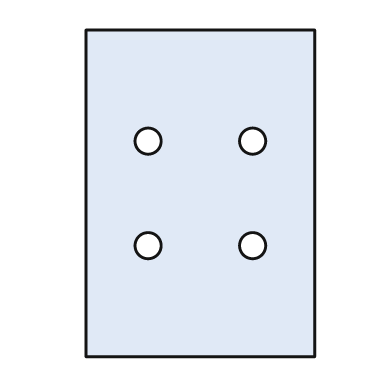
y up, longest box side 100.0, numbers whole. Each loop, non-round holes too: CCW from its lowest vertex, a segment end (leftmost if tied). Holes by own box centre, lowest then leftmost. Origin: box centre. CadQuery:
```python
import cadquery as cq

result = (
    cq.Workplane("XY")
    .moveTo(-35.0, -50.0)
    .lineTo(35.0, -50.0)
    .lineTo(35.0, 50.0)
    .lineTo(-35.0, 50.0)
    .close()
    .moveTo(-16.0, -16.0)
    .circle(4.0)
    .moveTo(16.0, -16.0)
    .circle(4.0)
    .moveTo(-16.0, 16.0)
    .circle(4.0)
    .moveTo(16.0, 16.0)
    .circle(4.0)
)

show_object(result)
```